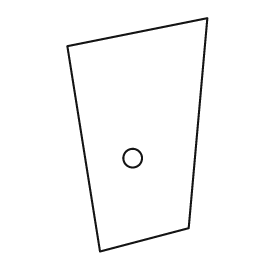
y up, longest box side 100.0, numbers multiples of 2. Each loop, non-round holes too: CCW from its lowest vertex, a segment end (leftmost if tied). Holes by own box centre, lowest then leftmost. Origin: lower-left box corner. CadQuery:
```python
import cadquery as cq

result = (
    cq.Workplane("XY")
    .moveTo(14.0, 0.0)
    .lineTo(52.0, 10.0)
    .lineTo(60.0, 100.0)
    .lineTo(0.0, 88.0)
    .close()
    .moveTo(28.0, 40.0)
    .circle(4.0)
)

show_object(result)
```